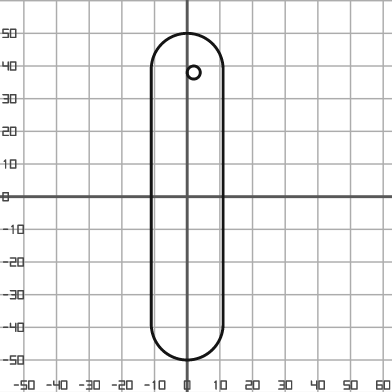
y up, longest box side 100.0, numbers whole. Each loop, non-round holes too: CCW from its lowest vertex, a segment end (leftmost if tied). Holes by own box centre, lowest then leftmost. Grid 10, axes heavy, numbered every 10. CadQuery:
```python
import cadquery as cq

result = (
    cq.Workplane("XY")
    .moveTo(-11.0, -39.0)
    .threePointArc((0.0, -50.0), (11.0, -39.0))
    .lineTo(11.0, 39.0)
    .threePointArc((0.0, 50.0), (-11.0, 39.0))
    .close()
    .moveTo(2.0, 38.0)
    .circle(2.0)
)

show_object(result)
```